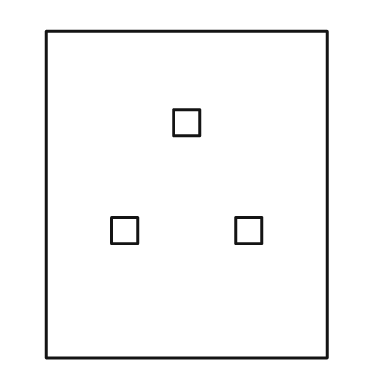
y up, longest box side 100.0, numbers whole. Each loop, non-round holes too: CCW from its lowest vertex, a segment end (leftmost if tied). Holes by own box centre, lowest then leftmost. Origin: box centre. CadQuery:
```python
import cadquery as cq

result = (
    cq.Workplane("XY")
    .moveTo(-43.0, -50.0)
    .lineTo(43.0, -50.0)
    .lineTo(43.0, 50.0)
    .lineTo(-43.0, 50.0)
    .close()
    .moveTo(-23.0, -15.0)
    .lineTo(-15.0, -15.0)
    .lineTo(-15.0, -7.0)
    .lineTo(-23.0, -7.0)
    .close()
    .moveTo(15.0, -15.0)
    .lineTo(23.0, -15.0)
    .lineTo(23.0, -7.0)
    .lineTo(15.0, -7.0)
    .close()
    .moveTo(-4.0, 18.0)
    .lineTo(4.0, 18.0)
    .lineTo(4.0, 26.0)
    .lineTo(-4.0, 26.0)
    .close()
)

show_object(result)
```